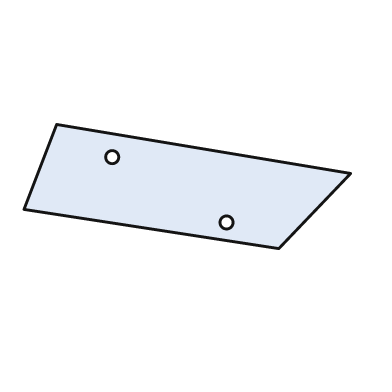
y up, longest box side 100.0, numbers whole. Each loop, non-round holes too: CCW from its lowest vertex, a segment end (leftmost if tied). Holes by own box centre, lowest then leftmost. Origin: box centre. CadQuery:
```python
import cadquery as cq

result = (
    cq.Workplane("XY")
    .moveTo(28.0, -19.0)
    .lineTo(50.0, 4.0)
    .lineTo(-40.0, 19.0)
    .lineTo(-50.0, -7.0)
    .close()
    .moveTo(12.0, -11.0)
    .circle(2.0)
    .moveTo(-23.0, 9.0)
    .circle(2.0)
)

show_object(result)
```